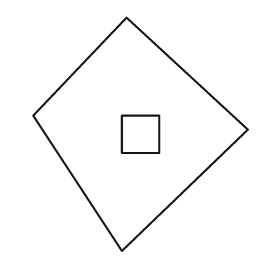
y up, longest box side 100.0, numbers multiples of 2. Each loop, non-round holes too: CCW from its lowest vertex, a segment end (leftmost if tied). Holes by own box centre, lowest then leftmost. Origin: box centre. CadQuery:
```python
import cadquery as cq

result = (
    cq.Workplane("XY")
    .moveTo(-8.0, -50.0)
    .lineTo(46.0, 2.0)
    .lineTo(-6.0, 50.0)
    .lineTo(-46.0, 8.0)
    .close()
    .moveTo(-8.0, -8.0)
    .lineTo(8.0, -8.0)
    .lineTo(8.0, 8.0)
    .lineTo(-8.0, 8.0)
    .close()
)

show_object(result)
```